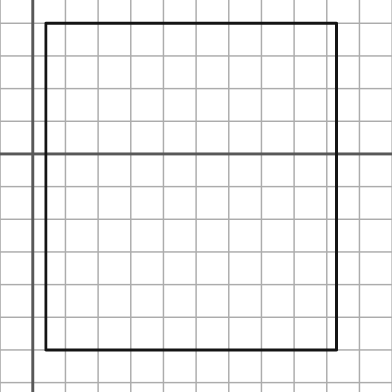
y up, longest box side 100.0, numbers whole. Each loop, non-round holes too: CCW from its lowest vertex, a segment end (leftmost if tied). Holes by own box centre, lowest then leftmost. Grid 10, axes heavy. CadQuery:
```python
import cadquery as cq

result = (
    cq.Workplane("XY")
    .moveTo(4.0, -60.0)
    .lineTo(93.0, -60.0)
    .lineTo(93.0, 40.0)
    .lineTo(4.0, 40.0)
    .close()
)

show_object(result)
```